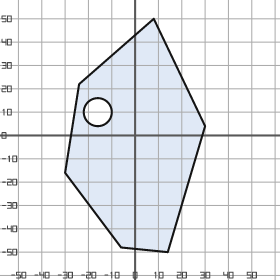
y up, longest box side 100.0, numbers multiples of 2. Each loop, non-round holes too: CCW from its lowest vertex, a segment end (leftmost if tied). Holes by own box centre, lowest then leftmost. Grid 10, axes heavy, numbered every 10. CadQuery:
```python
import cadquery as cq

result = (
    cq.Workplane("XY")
    .moveTo(14.0, -50.0)
    .lineTo(30.0, 4.0)
    .lineTo(8.0, 50.0)
    .lineTo(-24.0, 22.0)
    .lineTo(-30.0, -16.0)
    .lineTo(-6.0, -48.0)
    .close()
    .moveTo(-16.0, 10.0)
    .circle(6.0)
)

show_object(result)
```